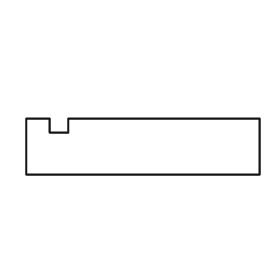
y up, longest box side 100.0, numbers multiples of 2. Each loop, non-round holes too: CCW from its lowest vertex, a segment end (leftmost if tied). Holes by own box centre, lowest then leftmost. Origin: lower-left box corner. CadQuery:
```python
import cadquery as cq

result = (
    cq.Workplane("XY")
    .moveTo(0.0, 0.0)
    .lineTo(100.0, 0.0)
    .lineTo(100.0, 24.0)
    .lineTo(18.0, 24.0)
    .lineTo(18.0, 18.0)
    .lineTo(10.0, 18.0)
    .lineTo(10.0, 24.0)
    .lineTo(0.0, 24.0)
    .close()
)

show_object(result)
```